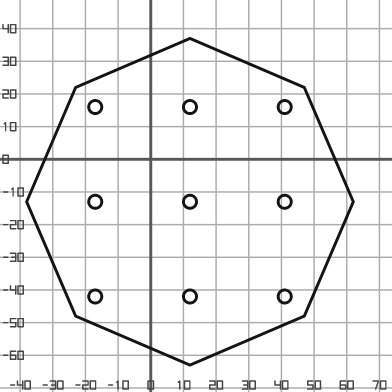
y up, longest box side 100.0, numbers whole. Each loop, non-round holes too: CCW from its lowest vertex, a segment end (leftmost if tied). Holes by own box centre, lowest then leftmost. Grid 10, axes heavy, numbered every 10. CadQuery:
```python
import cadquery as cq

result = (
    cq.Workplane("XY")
    .moveTo(12.0, -63.0)
    .lineTo(47.0, -48.0)
    .lineTo(62.0, -13.0)
    .lineTo(47.0, 22.0)
    .lineTo(12.0, 37.0)
    .lineTo(-23.0, 22.0)
    .lineTo(-38.0, -13.0)
    .lineTo(-23.0, -48.0)
    .close()
    .moveTo(-17.0, -42.0)
    .circle(2.0)
    .moveTo(12.0, -42.0)
    .circle(2.0)
    .moveTo(41.0, -42.0)
    .circle(2.0)
    .moveTo(-17.0, -13.0)
    .circle(2.0)
    .moveTo(12.0, -13.0)
    .circle(2.0)
    .moveTo(41.0, -13.0)
    .circle(2.0)
    .moveTo(-17.0, 16.0)
    .circle(2.0)
    .moveTo(12.0, 16.0)
    .circle(2.0)
    .moveTo(41.0, 16.0)
    .circle(2.0)
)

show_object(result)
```